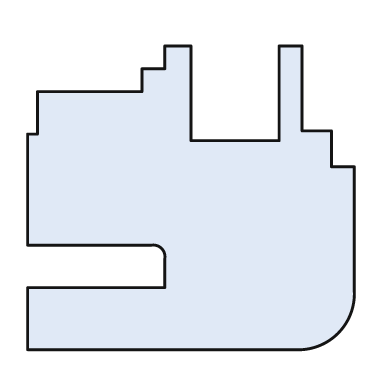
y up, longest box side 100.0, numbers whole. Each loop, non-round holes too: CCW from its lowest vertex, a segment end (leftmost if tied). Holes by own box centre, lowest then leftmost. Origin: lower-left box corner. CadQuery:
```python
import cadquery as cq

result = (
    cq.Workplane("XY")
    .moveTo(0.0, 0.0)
    .lineTo(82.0, 0.0)
    .threePointArc((95.0, 5.0), (100.0, 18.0))
    .lineTo(100.0, 56.0)
    .lineTo(93.0, 56.0)
    .lineTo(93.0, 67.0)
    .lineTo(84.0, 67.0)
    .lineTo(84.0, 93.0)
    .lineTo(77.0, 93.0)
    .lineTo(77.0, 64.0)
    .lineTo(50.0, 64.0)
    .lineTo(50.0, 93.0)
    .lineTo(42.0, 93.0)
    .lineTo(42.0, 86.0)
    .lineTo(35.0, 86.0)
    .lineTo(35.0, 79.0)
    .lineTo(3.0, 79.0)
    .lineTo(3.0, 66.0)
    .lineTo(0.0, 66.0)
    .lineTo(0.0, 32.0)
    .lineTo(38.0, 32.0)
    .threePointArc((41.0, 31.0), (42.0, 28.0))
    .lineTo(42.0, 19.0)
    .lineTo(0.0, 19.0)
    .close()
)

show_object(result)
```